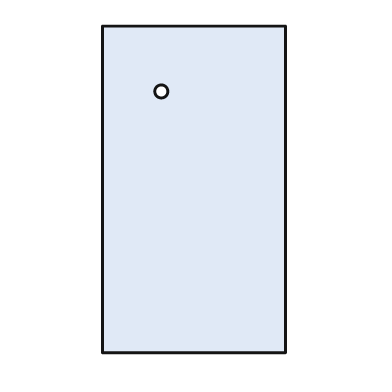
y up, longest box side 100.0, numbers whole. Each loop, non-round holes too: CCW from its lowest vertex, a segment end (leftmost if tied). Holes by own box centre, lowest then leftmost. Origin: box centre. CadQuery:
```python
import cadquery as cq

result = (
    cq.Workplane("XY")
    .moveTo(-28.0, -50.0)
    .lineTo(28.0, -50.0)
    .lineTo(28.0, 50.0)
    .lineTo(-28.0, 50.0)
    .close()
    .moveTo(-10.0, 30.0)
    .circle(2.0)
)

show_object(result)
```